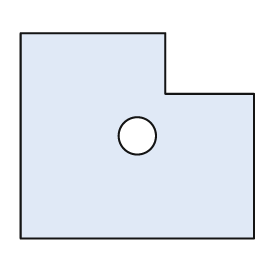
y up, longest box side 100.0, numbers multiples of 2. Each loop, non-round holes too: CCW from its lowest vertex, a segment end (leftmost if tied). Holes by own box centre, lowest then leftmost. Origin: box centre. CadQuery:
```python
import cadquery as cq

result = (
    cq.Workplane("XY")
    .moveTo(-50.0, -44.0)
    .lineTo(50.0, -44.0)
    .lineTo(50.0, 18.0)
    .lineTo(12.0, 18.0)
    .lineTo(12.0, 44.0)
    .lineTo(-50.0, 44.0)
    .close()
    .moveTo(0.0, 0.0)
    .circle(8.0)
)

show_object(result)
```